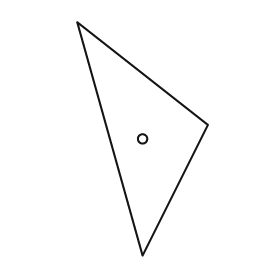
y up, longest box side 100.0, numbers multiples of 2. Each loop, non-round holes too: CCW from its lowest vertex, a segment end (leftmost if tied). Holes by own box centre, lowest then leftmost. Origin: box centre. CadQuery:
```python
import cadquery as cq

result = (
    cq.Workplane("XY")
    .moveTo(0.0, -50.0)
    .lineTo(28.0, 6.0)
    .lineTo(-28.0, 50.0)
    .close()
    .moveTo(0.0, 0.0)
    .circle(2.0)
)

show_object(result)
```